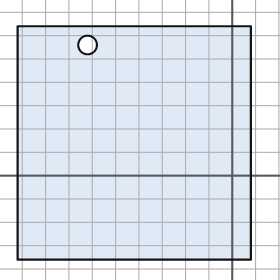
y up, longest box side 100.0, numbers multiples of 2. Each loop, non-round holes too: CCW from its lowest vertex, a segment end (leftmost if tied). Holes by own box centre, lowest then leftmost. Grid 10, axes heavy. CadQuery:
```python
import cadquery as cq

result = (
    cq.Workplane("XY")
    .moveTo(-92.0, -36.0)
    .lineTo(8.0, -36.0)
    .lineTo(8.0, 64.0)
    .lineTo(-92.0, 64.0)
    .close()
    .moveTo(-62.0, 56.0)
    .circle(4.0)
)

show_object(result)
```